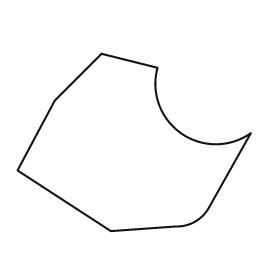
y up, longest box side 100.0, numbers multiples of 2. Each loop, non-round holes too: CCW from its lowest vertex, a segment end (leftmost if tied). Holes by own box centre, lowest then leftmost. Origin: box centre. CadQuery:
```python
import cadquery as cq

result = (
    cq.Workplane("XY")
    .moveTo(-10.0, -38.0)
    .lineTo(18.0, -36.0)
    .threePointArc((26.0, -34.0), (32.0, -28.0))
    .lineTo(50.0, 4.0)
    .threePointArc((20.0, 4.0), (10.0, 32.0))
    .lineTo(-14.0, 38.0)
    .lineTo(-34.0, 18.0)
    .lineTo(-50.0, -12.0)
    .close()
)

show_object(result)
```